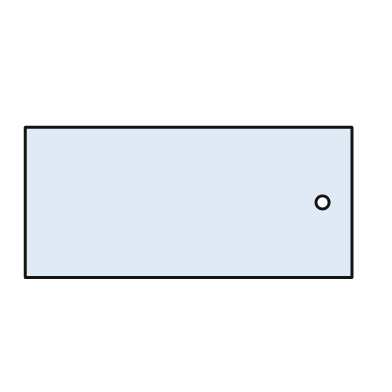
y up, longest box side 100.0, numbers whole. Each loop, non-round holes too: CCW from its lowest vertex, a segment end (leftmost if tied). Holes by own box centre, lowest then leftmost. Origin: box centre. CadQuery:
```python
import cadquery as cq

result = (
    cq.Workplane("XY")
    .moveTo(-50.0, -23.0)
    .lineTo(50.0, -23.0)
    .lineTo(50.0, 23.0)
    .lineTo(-50.0, 23.0)
    .close()
    .moveTo(41.0, 0.0)
    .circle(2.0)
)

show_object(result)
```